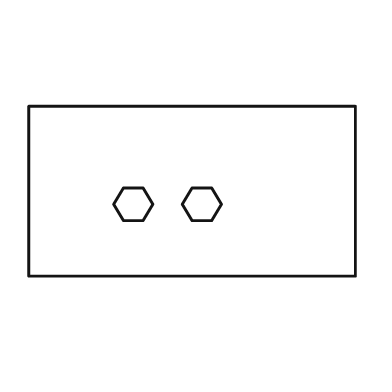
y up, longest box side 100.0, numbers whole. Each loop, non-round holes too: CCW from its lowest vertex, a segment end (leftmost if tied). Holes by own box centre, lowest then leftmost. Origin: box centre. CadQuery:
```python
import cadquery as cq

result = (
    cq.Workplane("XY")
    .moveTo(-50.0, -26.0)
    .lineTo(50.0, -26.0)
    .lineTo(50.0, 26.0)
    .lineTo(-50.0, 26.0)
    .close()
    .moveTo(-21.0, -9.0)
    .lineTo(-15.0, -9.0)
    .lineTo(-12.0, -4.0)
    .lineTo(-15.0, 1.0)
    .lineTo(-21.0, 1.0)
    .lineTo(-24.0, -4.0)
    .close()
    .moveTo(0.0, -9.0)
    .lineTo(6.0, -9.0)
    .lineTo(9.0, -4.0)
    .lineTo(6.0, 1.0)
    .lineTo(0.0, 1.0)
    .lineTo(-3.0, -4.0)
    .close()
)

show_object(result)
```